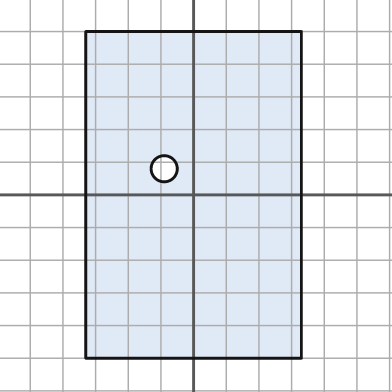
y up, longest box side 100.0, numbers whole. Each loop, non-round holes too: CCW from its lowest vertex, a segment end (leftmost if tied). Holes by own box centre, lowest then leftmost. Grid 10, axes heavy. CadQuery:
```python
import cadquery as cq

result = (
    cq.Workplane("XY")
    .moveTo(-33.0, -50.0)
    .lineTo(33.0, -50.0)
    .lineTo(33.0, 50.0)
    .lineTo(-33.0, 50.0)
    .close()
    .moveTo(-9.0, 8.0)
    .circle(4.0)
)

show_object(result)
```